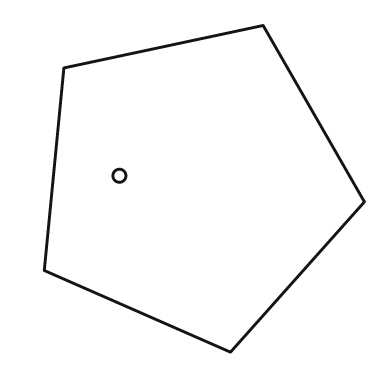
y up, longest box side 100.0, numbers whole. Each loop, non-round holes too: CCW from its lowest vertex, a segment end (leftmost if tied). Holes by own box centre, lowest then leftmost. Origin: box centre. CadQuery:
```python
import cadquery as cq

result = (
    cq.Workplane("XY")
    .moveTo(8.0, -50.0)
    .lineTo(49.0, -4.0)
    .lineTo(18.0, 50.0)
    .lineTo(-43.0, 37.0)
    .lineTo(-49.0, -25.0)
    .close()
    .moveTo(-26.0, 4.0)
    .circle(2.0)
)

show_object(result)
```